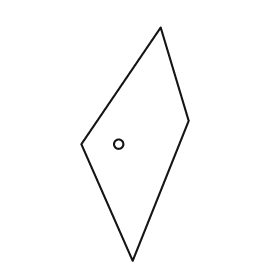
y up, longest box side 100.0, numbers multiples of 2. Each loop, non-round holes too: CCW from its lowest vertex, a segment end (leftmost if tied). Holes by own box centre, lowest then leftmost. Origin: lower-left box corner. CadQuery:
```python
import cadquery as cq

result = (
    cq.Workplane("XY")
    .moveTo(22.0, 0.0)
    .lineTo(46.0, 60.0)
    .lineTo(34.0, 100.0)
    .lineTo(0.0, 50.0)
    .close()
    .moveTo(16.0, 50.0)
    .circle(2.0)
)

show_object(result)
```